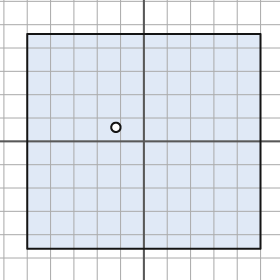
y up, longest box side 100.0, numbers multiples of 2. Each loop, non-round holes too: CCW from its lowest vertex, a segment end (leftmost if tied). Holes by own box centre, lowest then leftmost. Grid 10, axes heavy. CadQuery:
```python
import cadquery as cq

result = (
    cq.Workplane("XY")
    .moveTo(-50.0, -46.0)
    .lineTo(50.0, -46.0)
    .lineTo(50.0, 46.0)
    .lineTo(-50.0, 46.0)
    .close()
    .moveTo(-12.0, 6.0)
    .circle(2.0)
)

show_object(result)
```